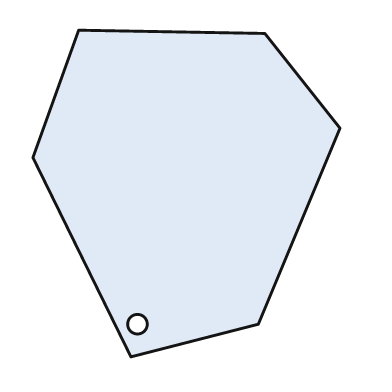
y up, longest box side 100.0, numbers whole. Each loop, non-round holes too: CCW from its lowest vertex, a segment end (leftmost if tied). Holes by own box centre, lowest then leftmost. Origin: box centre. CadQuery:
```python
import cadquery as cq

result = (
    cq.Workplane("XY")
    .moveTo(-17.0, -50.0)
    .lineTo(22.0, -40.0)
    .lineTo(47.0, 20.0)
    .lineTo(24.0, 49.0)
    .lineTo(-33.0, 50.0)
    .lineTo(-47.0, 11.0)
    .close()
    .moveTo(-15.0, -40.0)
    .circle(3.0)
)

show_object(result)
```